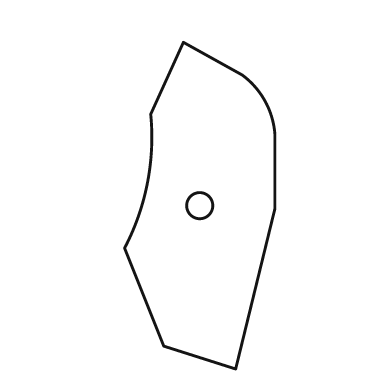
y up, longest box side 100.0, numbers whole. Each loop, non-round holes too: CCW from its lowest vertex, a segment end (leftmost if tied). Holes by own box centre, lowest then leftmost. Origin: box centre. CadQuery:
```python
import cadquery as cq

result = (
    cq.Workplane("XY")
    .moveTo(11.0, -50.0)
    .lineTo(23.0, -1.0)
    .lineTo(23.0, 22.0)
    .threePointArc((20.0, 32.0), (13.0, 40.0))
    .lineTo(-5.0, 50.0)
    .lineTo(-15.0, 28.0)
    .threePointArc((-16.0, 7.0), (-23.0, -13.0))
    .lineTo(-11.0, -43.0)
    .close()
    .moveTo(0.0, 0.0)
    .circle(4.0)
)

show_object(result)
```